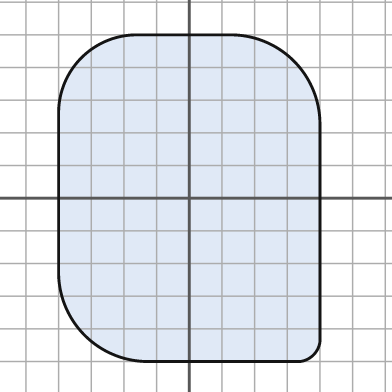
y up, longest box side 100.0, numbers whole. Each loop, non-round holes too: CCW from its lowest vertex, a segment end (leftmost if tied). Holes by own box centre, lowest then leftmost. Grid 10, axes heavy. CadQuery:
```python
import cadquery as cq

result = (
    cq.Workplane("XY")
    .moveTo(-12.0, -50.0)
    .lineTo(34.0, -50.0)
    .threePointArc((38.0, -48.0), (40.0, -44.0))
    .lineTo(40.0, 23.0)
    .threePointArc((32.0, 42.0), (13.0, 50.0))
    .lineTo(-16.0, 50.0)
    .threePointArc((-33.0, 43.0), (-40.0, 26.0))
    .lineTo(-40.0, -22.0)
    .threePointArc((-32.0, -42.0), (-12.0, -50.0))
    .close()
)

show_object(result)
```